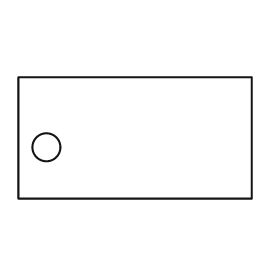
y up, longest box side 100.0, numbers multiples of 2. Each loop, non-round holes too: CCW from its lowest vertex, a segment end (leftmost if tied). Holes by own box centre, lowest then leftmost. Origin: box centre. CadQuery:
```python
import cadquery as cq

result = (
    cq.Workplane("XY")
    .moveTo(-50.0, -26.0)
    .lineTo(50.0, -26.0)
    .lineTo(50.0, 26.0)
    .lineTo(-50.0, 26.0)
    .close()
    .moveTo(-38.0, -4.0)
    .circle(6.0)
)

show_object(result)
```